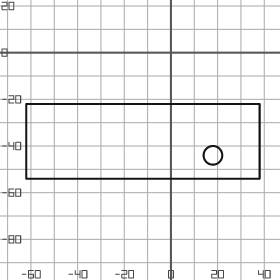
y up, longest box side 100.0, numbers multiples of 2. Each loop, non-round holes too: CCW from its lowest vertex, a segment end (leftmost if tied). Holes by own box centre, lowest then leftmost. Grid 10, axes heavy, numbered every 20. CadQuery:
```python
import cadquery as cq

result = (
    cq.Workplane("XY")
    .moveTo(-62.0, -54.0)
    .lineTo(38.0, -54.0)
    .lineTo(38.0, -22.0)
    .lineTo(-62.0, -22.0)
    .close()
    .moveTo(18.0, -44.0)
    .circle(4.0)
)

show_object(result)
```